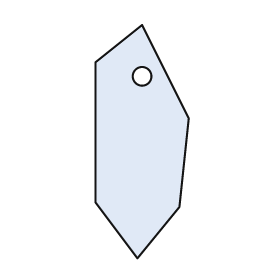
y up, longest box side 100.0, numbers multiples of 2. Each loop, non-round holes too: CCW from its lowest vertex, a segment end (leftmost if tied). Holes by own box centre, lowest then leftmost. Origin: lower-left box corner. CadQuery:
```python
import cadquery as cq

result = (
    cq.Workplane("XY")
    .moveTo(18.0, 0.0)
    .lineTo(36.0, 22.0)
    .lineTo(40.0, 60.0)
    .lineTo(20.0, 100.0)
    .lineTo(0.0, 84.0)
    .lineTo(0.0, 24.0)
    .close()
    .moveTo(20.0, 78.0)
    .circle(4.0)
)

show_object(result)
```